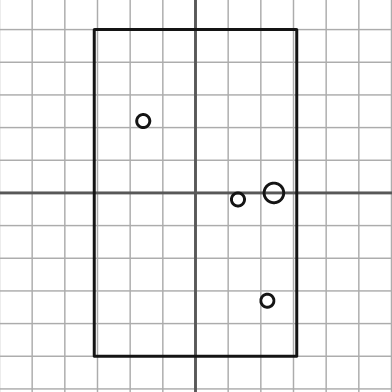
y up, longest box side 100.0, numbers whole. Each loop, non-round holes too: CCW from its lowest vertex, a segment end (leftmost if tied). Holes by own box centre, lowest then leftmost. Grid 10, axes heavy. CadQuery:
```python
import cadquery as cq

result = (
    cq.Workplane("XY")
    .moveTo(-31.0, -50.0)
    .lineTo(31.0, -50.0)
    .lineTo(31.0, 50.0)
    .lineTo(-31.0, 50.0)
    .close()
    .moveTo(22.0, -33.0)
    .circle(2.0)
    .moveTo(13.0, -2.0)
    .circle(2.0)
    .moveTo(24.0, 0.0)
    .circle(3.0)
    .moveTo(-16.0, 22.0)
    .circle(2.0)
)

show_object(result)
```